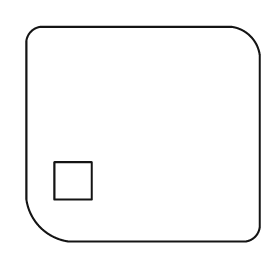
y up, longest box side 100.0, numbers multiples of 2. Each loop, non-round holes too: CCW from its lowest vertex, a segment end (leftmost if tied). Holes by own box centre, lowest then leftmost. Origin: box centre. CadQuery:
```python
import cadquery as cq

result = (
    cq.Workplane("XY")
    .moveTo(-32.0, -46.0)
    .lineTo(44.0, -46.0)
    .threePointArc((48.0, -44.0), (50.0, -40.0))
    .lineTo(50.0, 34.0)
    .threePointArc((46.0, 42.0), (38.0, 46.0))
    .lineTo(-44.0, 46.0)
    .threePointArc((-48.0, 44.0), (-50.0, 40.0))
    .lineTo(-50.0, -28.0)
    .threePointArc((-44.0, -40.0), (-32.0, -46.0))
    .close()
    .moveTo(-38.0, -28.0)
    .lineTo(-22.0, -28.0)
    .lineTo(-22.0, -12.0)
    .lineTo(-38.0, -12.0)
    .close()
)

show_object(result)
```